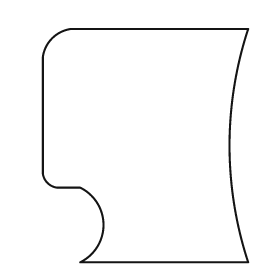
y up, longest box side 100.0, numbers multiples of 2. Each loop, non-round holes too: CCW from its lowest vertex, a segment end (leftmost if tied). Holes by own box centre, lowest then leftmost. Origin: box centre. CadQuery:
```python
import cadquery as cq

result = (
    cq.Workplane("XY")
    .moveTo(-28.0, -50.0)
    .lineTo(44.0, -50.0)
    .threePointArc((36.0, 0.0), (44.0, 50.0))
    .lineTo(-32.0, 50.0)
    .threePointArc((-40.0, 46.0), (-44.0, 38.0))
    .lineTo(-44.0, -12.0)
    .threePointArc((-42.0, -16.0), (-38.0, -18.0))
    .lineTo(-28.0, -18.0)
    .threePointArc((-18.0, -34.0), (-28.0, -50.0))
    .close()
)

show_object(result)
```